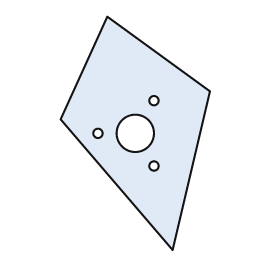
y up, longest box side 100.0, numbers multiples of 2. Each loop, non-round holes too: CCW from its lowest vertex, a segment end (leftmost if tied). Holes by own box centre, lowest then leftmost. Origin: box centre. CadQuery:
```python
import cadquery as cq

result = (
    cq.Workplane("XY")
    .moveTo(16.0, -50.0)
    .lineTo(32.0, 18.0)
    .lineTo(-12.0, 50.0)
    .lineTo(-32.0, 6.0)
    .close()
    .moveTo(8.0, -14.0)
    .circle(2.0)
    .moveTo(-16.0, 0.0)
    .circle(2.0)
    .moveTo(0.0, 0.0)
    .circle(8.0)
    .moveTo(8.0, 14.0)
    .circle(2.0)
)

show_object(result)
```